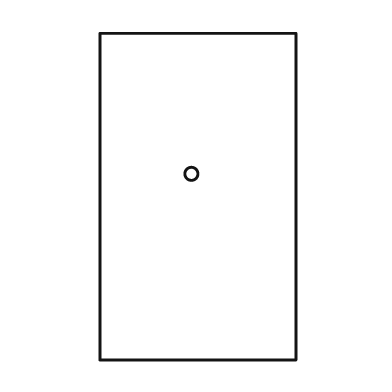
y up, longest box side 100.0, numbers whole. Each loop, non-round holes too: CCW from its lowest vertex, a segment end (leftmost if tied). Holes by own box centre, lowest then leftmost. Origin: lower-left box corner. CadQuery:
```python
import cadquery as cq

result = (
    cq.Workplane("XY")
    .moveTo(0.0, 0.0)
    .lineTo(60.0, 0.0)
    .lineTo(60.0, 100.0)
    .lineTo(0.0, 100.0)
    .close()
    .moveTo(28.0, 57.0)
    .circle(2.0)
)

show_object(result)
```